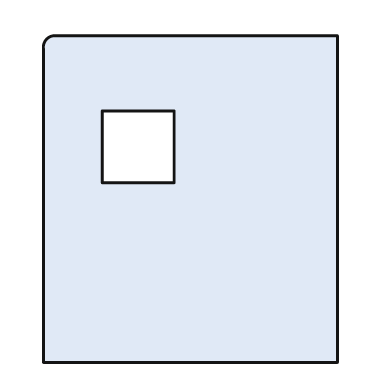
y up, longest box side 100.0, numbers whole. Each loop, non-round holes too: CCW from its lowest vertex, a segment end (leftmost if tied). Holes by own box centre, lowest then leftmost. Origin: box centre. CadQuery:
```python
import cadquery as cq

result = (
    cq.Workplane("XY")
    .moveTo(-45.0, -50.0)
    .lineTo(45.0, -50.0)
    .lineTo(45.0, 50.0)
    .lineTo(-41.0, 50.0)
    .threePointArc((-44.0, 49.0), (-45.0, 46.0))
    .close()
    .moveTo(-27.0, 5.0)
    .lineTo(-5.0, 5.0)
    .lineTo(-5.0, 27.0)
    .lineTo(-27.0, 27.0)
    .close()
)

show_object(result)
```